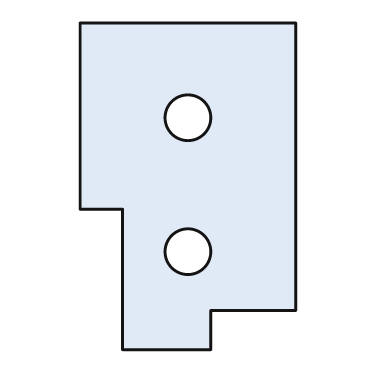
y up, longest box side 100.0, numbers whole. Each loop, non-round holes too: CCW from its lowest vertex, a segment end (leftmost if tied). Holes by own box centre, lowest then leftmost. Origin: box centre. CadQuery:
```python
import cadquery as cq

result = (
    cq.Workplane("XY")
    .moveTo(-20.0, -50.0)
    .lineTo(7.0, -50.0)
    .lineTo(7.0, -38.0)
    .lineTo(33.0, -38.0)
    .lineTo(33.0, 50.0)
    .lineTo(-33.0, 50.0)
    .lineTo(-33.0, -7.0)
    .lineTo(-20.0, -7.0)
    .close()
    .moveTo(0.0, -20.0)
    .circle(7.0)
    .moveTo(0.0, 21.0)
    .circle(7.0)
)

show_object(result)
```